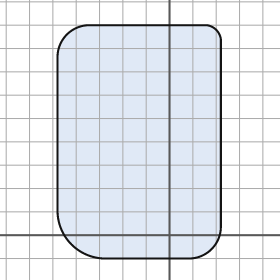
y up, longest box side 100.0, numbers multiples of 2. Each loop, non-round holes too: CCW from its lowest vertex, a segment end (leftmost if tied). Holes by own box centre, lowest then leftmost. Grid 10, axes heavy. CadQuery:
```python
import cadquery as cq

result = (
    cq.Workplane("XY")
    .moveTo(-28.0, -10.0)
    .lineTo(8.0, -10.0)
    .threePointArc((18.0, -6.0), (22.0, 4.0))
    .lineTo(22.0, 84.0)
    .threePointArc((20.0, 88.0), (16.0, 90.0))
    .lineTo(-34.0, 90.0)
    .threePointArc((-44.0, 86.0), (-48.0, 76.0))
    .lineTo(-48.0, 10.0)
    .threePointArc((-42.0, -4.0), (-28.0, -10.0))
    .close()
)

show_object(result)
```